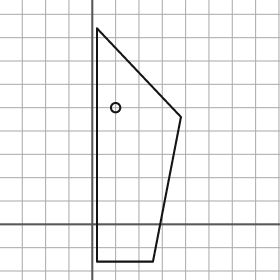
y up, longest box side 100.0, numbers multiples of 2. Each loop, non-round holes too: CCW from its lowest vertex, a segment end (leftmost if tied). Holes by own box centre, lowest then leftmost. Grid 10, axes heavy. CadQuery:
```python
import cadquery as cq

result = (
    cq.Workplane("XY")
    .moveTo(2.0, -16.0)
    .lineTo(26.0, -16.0)
    .lineTo(38.0, 46.0)
    .lineTo(2.0, 84.0)
    .close()
    .moveTo(10.0, 50.0)
    .circle(2.0)
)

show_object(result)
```